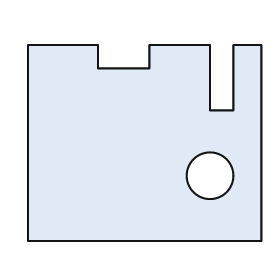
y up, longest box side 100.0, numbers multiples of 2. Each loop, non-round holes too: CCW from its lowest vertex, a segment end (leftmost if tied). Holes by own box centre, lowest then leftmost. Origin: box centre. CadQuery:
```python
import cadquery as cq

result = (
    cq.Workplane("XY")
    .moveTo(-50.0, -42.0)
    .lineTo(50.0, -42.0)
    .lineTo(50.0, 42.0)
    .lineTo(38.0, 42.0)
    .lineTo(38.0, 14.0)
    .lineTo(28.0, 14.0)
    .lineTo(28.0, 42.0)
    .lineTo(2.0, 42.0)
    .lineTo(2.0, 32.0)
    .lineTo(-20.0, 32.0)
    .lineTo(-20.0, 42.0)
    .lineTo(-50.0, 42.0)
    .close()
    .moveTo(28.0, -14.0)
    .circle(10.0)
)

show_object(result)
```